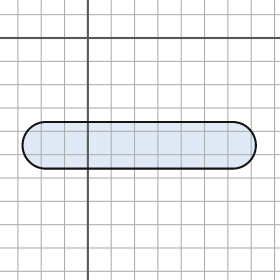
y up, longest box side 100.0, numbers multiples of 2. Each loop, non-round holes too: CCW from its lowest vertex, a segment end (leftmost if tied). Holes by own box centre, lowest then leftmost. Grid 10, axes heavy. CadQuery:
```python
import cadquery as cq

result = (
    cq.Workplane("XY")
    .moveTo(-18.0, -56.0)
    .lineTo(62.0, -56.0)
    .threePointArc((72.0, -46.0), (62.0, -36.0))
    .lineTo(-18.0, -36.0)
    .threePointArc((-28.0, -46.0), (-18.0, -56.0))
    .close()
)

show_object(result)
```